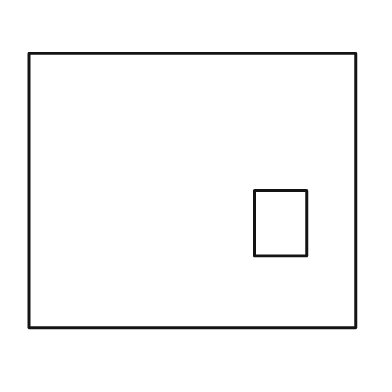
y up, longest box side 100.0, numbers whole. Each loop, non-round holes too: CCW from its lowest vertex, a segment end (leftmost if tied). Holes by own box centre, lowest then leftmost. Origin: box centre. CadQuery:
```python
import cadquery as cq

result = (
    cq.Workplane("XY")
    .moveTo(-50.0, -42.0)
    .lineTo(50.0, -42.0)
    .lineTo(50.0, 42.0)
    .lineTo(-50.0, 42.0)
    .close()
    .moveTo(19.0, -20.0)
    .lineTo(35.0, -20.0)
    .lineTo(35.0, 0.0)
    .lineTo(19.0, 0.0)
    .close()
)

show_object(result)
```